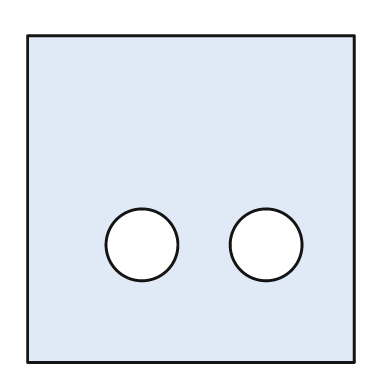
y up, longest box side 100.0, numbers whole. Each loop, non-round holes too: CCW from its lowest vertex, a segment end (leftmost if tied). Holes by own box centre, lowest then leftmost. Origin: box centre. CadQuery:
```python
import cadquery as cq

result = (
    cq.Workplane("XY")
    .moveTo(-50.0, -50.0)
    .lineTo(50.0, -50.0)
    .lineTo(50.0, 50.0)
    .lineTo(-50.0, 50.0)
    .close()
    .moveTo(-15.0, -14.0)
    .circle(11.0)
    .moveTo(23.0, -14.0)
    .circle(11.0)
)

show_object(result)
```